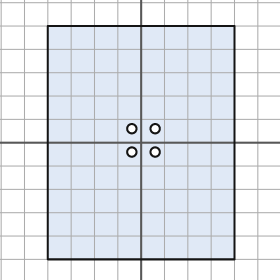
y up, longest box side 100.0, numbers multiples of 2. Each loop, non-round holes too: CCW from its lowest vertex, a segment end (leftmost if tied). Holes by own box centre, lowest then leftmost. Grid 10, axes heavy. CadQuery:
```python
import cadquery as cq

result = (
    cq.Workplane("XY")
    .moveTo(-40.0, -50.0)
    .lineTo(40.0, -50.0)
    .lineTo(40.0, 50.0)
    .lineTo(-40.0, 50.0)
    .close()
    .moveTo(-4.0, -4.0)
    .circle(2.0)
    .moveTo(6.0, -4.0)
    .circle(2.0)
    .moveTo(-4.0, 6.0)
    .circle(2.0)
    .moveTo(6.0, 6.0)
    .circle(2.0)
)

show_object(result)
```